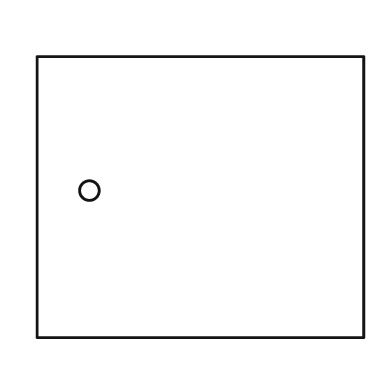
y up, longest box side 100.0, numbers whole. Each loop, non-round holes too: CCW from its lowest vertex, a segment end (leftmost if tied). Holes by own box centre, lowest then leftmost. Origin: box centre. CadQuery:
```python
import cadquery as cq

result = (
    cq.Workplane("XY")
    .moveTo(-50.0, -43.0)
    .lineTo(50.0, -43.0)
    .lineTo(50.0, 43.0)
    .lineTo(-50.0, 43.0)
    .close()
    .moveTo(-34.0, 2.0)
    .circle(3.0)
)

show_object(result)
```